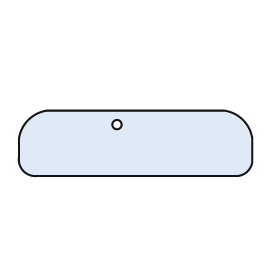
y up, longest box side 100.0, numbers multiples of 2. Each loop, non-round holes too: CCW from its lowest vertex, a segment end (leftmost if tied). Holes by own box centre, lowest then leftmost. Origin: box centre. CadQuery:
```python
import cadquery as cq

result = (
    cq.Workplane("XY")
    .moveTo(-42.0, -14.0)
    .lineTo(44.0, -14.0)
    .threePointArc((48.0, -12.0), (50.0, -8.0))
    .lineTo(50.0, 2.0)
    .threePointArc((46.0, 10.0), (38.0, 14.0))
    .lineTo(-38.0, 14.0)
    .threePointArc((-46.0, 10.0), (-50.0, 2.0))
    .lineTo(-50.0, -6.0)
    .threePointArc((-48.0, -12.0), (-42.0, -14.0))
    .close()
    .moveTo(-8.0, 8.0)
    .circle(2.0)
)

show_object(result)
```